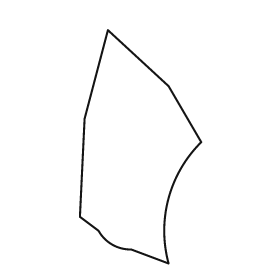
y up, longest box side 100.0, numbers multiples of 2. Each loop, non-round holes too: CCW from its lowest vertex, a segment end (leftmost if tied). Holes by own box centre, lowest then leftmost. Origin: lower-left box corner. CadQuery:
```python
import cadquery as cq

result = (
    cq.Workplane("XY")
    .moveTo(38.0, 0.0)
    .threePointArc((38.0, 28.0), (52.0, 52.0))
    .lineTo(38.0, 76.0)
    .lineTo(12.0, 100.0)
    .lineTo(2.0, 62.0)
    .lineTo(0.0, 20.0)
    .lineTo(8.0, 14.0)
    .threePointArc((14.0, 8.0), (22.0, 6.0))
    .close()
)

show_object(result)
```